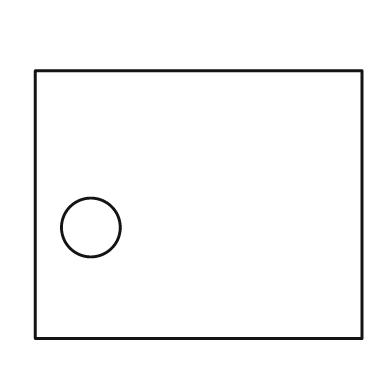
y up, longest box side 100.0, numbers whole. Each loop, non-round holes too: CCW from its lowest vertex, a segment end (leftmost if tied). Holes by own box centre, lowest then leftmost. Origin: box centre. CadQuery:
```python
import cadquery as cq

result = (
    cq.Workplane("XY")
    .moveTo(-50.0, -41.0)
    .lineTo(50.0, -41.0)
    .lineTo(50.0, 41.0)
    .lineTo(-50.0, 41.0)
    .close()
    .moveTo(-33.0, -7.0)
    .circle(9.0)
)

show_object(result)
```